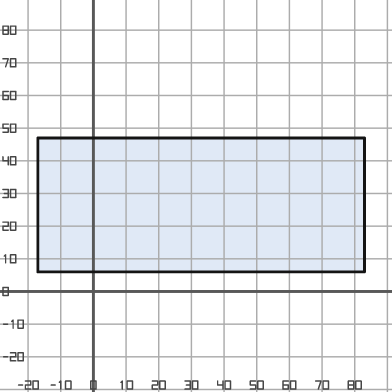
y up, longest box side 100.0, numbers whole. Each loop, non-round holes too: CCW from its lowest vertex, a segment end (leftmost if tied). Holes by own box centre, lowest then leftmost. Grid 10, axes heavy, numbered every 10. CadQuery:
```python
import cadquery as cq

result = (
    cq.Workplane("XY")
    .moveTo(-17.0, 6.0)
    .lineTo(83.0, 6.0)
    .lineTo(83.0, 47.0)
    .lineTo(-17.0, 47.0)
    .close()
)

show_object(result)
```